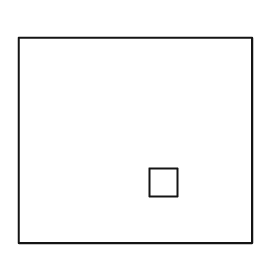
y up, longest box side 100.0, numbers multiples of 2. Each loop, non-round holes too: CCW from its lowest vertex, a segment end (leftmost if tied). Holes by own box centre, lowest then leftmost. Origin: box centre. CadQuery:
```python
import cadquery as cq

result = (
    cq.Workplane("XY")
    .moveTo(-50.0, -44.0)
    .lineTo(50.0, -44.0)
    .lineTo(50.0, 44.0)
    .lineTo(-50.0, 44.0)
    .close()
    .moveTo(6.0, -24.0)
    .lineTo(18.0, -24.0)
    .lineTo(18.0, -12.0)
    .lineTo(6.0, -12.0)
    .close()
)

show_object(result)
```